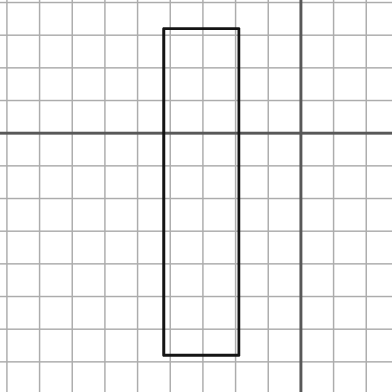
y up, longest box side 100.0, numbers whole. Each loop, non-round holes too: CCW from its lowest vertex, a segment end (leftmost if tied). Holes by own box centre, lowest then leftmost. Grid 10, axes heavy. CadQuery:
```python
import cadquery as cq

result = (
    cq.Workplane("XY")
    .moveTo(-42.0, -68.0)
    .lineTo(-19.0, -68.0)
    .lineTo(-19.0, 32.0)
    .lineTo(-42.0, 32.0)
    .close()
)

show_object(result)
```